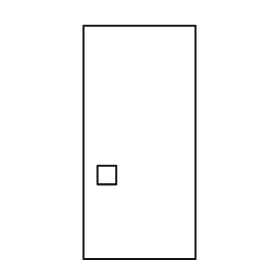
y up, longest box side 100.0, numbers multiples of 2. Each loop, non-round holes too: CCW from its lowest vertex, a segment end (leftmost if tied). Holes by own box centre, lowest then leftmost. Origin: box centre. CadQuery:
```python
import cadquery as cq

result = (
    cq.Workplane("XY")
    .moveTo(-24.0, -50.0)
    .lineTo(24.0, -50.0)
    .lineTo(24.0, 50.0)
    .lineTo(-24.0, 50.0)
    .close()
    .moveTo(-18.0, -18.0)
    .lineTo(-10.0, -18.0)
    .lineTo(-10.0, -10.0)
    .lineTo(-18.0, -10.0)
    .close()
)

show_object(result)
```